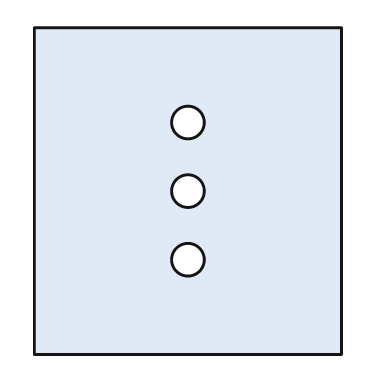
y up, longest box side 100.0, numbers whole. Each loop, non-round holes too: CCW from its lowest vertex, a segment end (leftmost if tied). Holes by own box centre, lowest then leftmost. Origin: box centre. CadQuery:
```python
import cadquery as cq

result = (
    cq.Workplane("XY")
    .moveTo(-47.0, -50.0)
    .lineTo(47.0, -50.0)
    .lineTo(47.0, 50.0)
    .lineTo(-47.0, 50.0)
    .close()
    .moveTo(0.0, -21.0)
    .circle(5.0)
    .moveTo(0.0, 0.0)
    .circle(5.0)
    .moveTo(0.0, 21.0)
    .circle(5.0)
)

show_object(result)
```